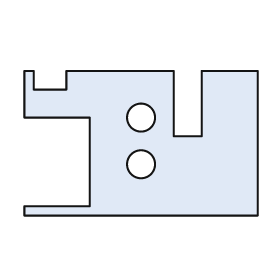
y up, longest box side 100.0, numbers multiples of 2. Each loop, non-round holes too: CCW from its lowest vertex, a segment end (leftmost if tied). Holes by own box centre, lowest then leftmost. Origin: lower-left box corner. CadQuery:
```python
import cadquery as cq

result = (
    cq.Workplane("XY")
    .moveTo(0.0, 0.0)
    .lineTo(100.0, 0.0)
    .lineTo(100.0, 62.0)
    .lineTo(76.0, 62.0)
    .lineTo(76.0, 34.0)
    .lineTo(64.0, 34.0)
    .lineTo(64.0, 62.0)
    .lineTo(18.0, 62.0)
    .lineTo(18.0, 54.0)
    .lineTo(4.0, 54.0)
    .lineTo(4.0, 62.0)
    .lineTo(0.0, 62.0)
    .lineTo(0.0, 42.0)
    .lineTo(28.0, 42.0)
    .lineTo(28.0, 4.0)
    .lineTo(0.0, 4.0)
    .close()
    .moveTo(50.0, 22.0)
    .circle(6.0)
    .moveTo(50.0, 42.0)
    .circle(6.0)
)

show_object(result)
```